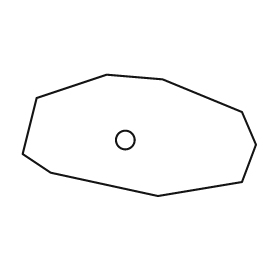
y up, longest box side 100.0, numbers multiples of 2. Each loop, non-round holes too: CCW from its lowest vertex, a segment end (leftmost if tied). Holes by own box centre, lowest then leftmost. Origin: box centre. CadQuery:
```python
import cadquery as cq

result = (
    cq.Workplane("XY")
    .moveTo(8.0, -26.0)
    .lineTo(44.0, -20.0)
    .lineTo(50.0, -4.0)
    .lineTo(44.0, 10.0)
    .lineTo(10.0, 24.0)
    .lineTo(-14.0, 26.0)
    .lineTo(-44.0, 16.0)
    .lineTo(-50.0, -8.0)
    .lineTo(-38.0, -16.0)
    .close()
    .moveTo(-6.0, -2.0)
    .circle(4.0)
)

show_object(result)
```